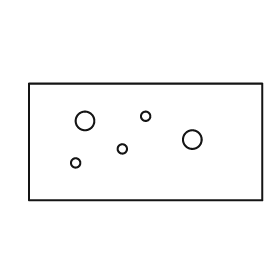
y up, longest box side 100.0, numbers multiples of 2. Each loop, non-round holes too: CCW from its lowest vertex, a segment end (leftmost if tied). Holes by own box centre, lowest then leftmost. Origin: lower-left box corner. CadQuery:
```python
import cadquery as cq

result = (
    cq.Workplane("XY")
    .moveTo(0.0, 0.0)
    .lineTo(100.0, 0.0)
    .lineTo(100.0, 50.0)
    .lineTo(0.0, 50.0)
    .close()
    .moveTo(20.0, 16.0)
    .circle(2.0)
    .moveTo(40.0, 22.0)
    .circle(2.0)
    .moveTo(70.0, 26.0)
    .circle(4.0)
    .moveTo(24.0, 34.0)
    .circle(4.0)
    .moveTo(50.0, 36.0)
    .circle(2.0)
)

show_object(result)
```